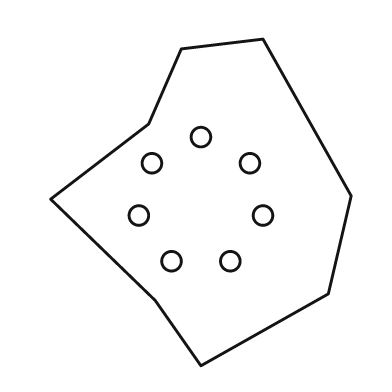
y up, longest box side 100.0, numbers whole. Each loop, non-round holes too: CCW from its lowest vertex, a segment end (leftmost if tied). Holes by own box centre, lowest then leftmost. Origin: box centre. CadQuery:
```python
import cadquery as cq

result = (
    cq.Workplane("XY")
    .moveTo(0.0, -50.0)
    .lineTo(39.0, -28.0)
    .lineTo(46.0, 2.0)
    .lineTo(19.0, 50.0)
    .lineTo(-6.0, 47.0)
    .lineTo(-16.0, 24.0)
    .lineTo(-46.0, 1.0)
    .lineTo(-14.0, -30.0)
    .close()
    .moveTo(-9.0, -18.0)
    .circle(3.0)
    .moveTo(9.0, -18.0)
    .circle(3.0)
    .moveTo(-19.0, -4.0)
    .circle(3.0)
    .moveTo(19.0, -4.0)
    .circle(3.0)
    .moveTo(-15.0, 12.0)
    .circle(3.0)
    .moveTo(15.0, 12.0)
    .circle(3.0)
    .moveTo(0.0, 20.0)
    .circle(3.0)
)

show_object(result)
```